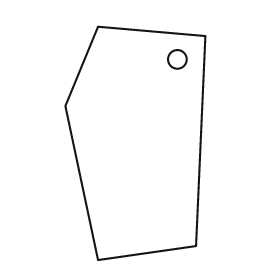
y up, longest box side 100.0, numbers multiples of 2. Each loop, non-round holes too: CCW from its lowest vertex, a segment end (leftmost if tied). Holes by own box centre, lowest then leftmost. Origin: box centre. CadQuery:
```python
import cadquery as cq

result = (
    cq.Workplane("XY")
    .moveTo(-16.0, -50.0)
    .lineTo(26.0, -44.0)
    .lineTo(30.0, 46.0)
    .lineTo(-16.0, 50.0)
    .lineTo(-30.0, 16.0)
    .close()
    .moveTo(18.0, 36.0)
    .circle(4.0)
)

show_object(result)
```